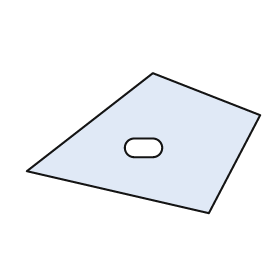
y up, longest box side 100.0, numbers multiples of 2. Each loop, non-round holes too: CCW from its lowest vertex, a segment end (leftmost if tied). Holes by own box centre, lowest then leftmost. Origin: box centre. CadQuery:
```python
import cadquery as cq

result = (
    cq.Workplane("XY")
    .moveTo(28.0, -30.0)
    .lineTo(50.0, 12.0)
    .lineTo(4.0, 30.0)
    .lineTo(-50.0, -12.0)
    .close()
    .moveTo(-4.0, -6.0)
    .lineTo(4.0, -6.0)
    .threePointArc((8.0, -2.0), (4.0, 2.0))
    .lineTo(-4.0, 2.0)
    .threePointArc((-8.0, -2.0), (-4.0, -6.0))
    .close()
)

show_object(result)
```